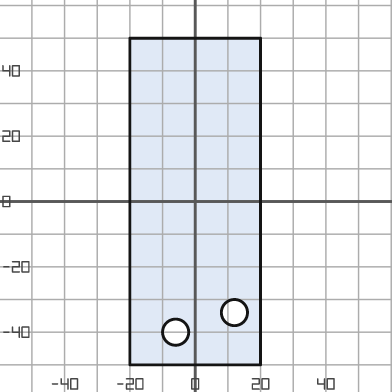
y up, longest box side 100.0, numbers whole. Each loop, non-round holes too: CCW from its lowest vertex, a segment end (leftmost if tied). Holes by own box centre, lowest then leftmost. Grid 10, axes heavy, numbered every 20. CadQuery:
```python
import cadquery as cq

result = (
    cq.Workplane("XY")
    .moveTo(-20.0, -50.0)
    .lineTo(20.0, -50.0)
    .lineTo(20.0, 50.0)
    .lineTo(-20.0, 50.0)
    .close()
    .moveTo(-6.0, -40.0)
    .circle(4.0)
    .moveTo(12.0, -34.0)
    .circle(4.0)
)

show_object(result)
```